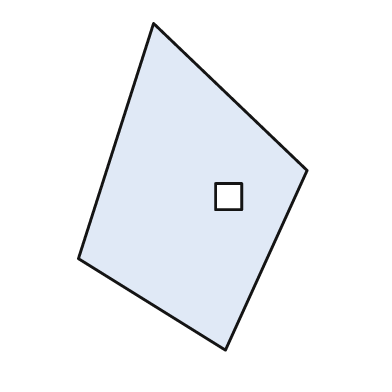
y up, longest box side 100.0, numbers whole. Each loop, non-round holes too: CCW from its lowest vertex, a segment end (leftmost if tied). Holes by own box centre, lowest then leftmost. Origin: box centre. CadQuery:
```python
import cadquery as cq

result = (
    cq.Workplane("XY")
    .moveTo(10.0, -50.0)
    .lineTo(35.0, 5.0)
    .lineTo(-12.0, 50.0)
    .lineTo(-35.0, -22.0)
    .close()
    .moveTo(7.0, -7.0)
    .lineTo(15.0, -7.0)
    .lineTo(15.0, 1.0)
    .lineTo(7.0, 1.0)
    .close()
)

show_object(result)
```